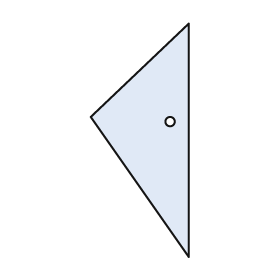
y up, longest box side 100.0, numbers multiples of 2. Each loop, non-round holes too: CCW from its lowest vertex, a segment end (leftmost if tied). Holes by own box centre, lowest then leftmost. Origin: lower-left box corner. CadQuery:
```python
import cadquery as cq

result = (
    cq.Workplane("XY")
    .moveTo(42.0, 0.0)
    .lineTo(42.0, 100.0)
    .lineTo(0.0, 60.0)
    .close()
    .moveTo(34.0, 58.0)
    .circle(2.0)
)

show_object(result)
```